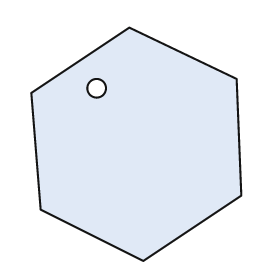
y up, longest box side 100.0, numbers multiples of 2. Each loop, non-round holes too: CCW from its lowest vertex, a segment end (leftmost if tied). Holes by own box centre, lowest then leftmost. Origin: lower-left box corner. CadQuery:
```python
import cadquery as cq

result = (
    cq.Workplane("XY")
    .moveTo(48.0, 0.0)
    .lineTo(90.0, 28.0)
    .lineTo(88.0, 78.0)
    .lineTo(42.0, 100.0)
    .lineTo(0.0, 72.0)
    .lineTo(4.0, 22.0)
    .close()
    .moveTo(28.0, 74.0)
    .circle(4.0)
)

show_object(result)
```